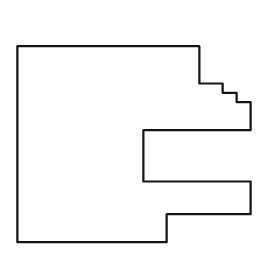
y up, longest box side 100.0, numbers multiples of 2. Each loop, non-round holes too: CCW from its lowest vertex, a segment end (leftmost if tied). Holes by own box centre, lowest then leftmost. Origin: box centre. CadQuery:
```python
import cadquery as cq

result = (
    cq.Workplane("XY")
    .moveTo(-50.0, -42.0)
    .lineTo(14.0, -42.0)
    .lineTo(14.0, -30.0)
    .lineTo(50.0, -30.0)
    .lineTo(50.0, -16.0)
    .lineTo(4.0, -16.0)
    .lineTo(4.0, 6.0)
    .lineTo(50.0, 6.0)
    .lineTo(50.0, 18.0)
    .lineTo(44.0, 18.0)
    .lineTo(44.0, 22.0)
    .lineTo(38.0, 22.0)
    .lineTo(38.0, 26.0)
    .lineTo(28.0, 26.0)
    .lineTo(28.0, 42.0)
    .lineTo(-50.0, 42.0)
    .close()
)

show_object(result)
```